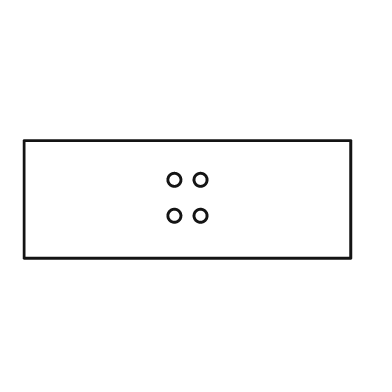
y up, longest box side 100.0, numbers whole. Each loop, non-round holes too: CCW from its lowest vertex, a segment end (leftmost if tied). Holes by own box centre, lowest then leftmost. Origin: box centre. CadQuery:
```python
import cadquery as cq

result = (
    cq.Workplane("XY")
    .moveTo(-50.0, -18.0)
    .lineTo(50.0, -18.0)
    .lineTo(50.0, 18.0)
    .lineTo(-50.0, 18.0)
    .close()
    .moveTo(-4.0, -5.0)
    .circle(2.0)
    .moveTo(4.0, -5.0)
    .circle(2.0)
    .moveTo(-4.0, 6.0)
    .circle(2.0)
    .moveTo(4.0, 6.0)
    .circle(2.0)
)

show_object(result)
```